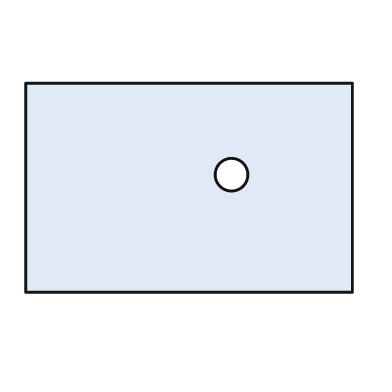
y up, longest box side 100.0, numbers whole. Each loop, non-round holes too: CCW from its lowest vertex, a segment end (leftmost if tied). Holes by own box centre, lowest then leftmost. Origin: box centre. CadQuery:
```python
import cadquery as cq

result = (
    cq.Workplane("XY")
    .moveTo(-50.0, -32.0)
    .lineTo(50.0, -32.0)
    .lineTo(50.0, 32.0)
    .lineTo(-50.0, 32.0)
    .close()
    .moveTo(13.0, 4.0)
    .circle(5.0)
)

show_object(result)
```